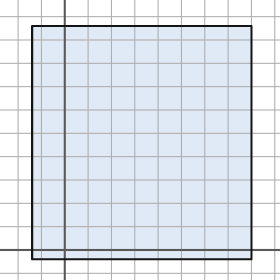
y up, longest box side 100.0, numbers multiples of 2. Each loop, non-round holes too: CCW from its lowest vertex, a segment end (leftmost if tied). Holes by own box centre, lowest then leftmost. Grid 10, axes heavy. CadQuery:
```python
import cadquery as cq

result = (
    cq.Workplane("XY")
    .moveTo(-14.0, -4.0)
    .lineTo(80.0, -4.0)
    .lineTo(80.0, 96.0)
    .lineTo(-14.0, 96.0)
    .close()
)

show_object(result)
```